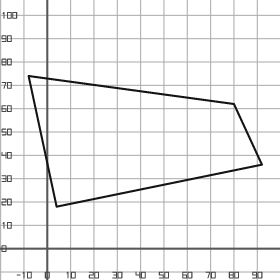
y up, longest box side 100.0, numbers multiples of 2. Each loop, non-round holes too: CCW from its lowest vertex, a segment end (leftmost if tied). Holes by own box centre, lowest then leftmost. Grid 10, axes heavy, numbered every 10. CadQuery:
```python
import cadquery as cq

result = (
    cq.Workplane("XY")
    .moveTo(4.0, 18.0)
    .lineTo(92.0, 36.0)
    .lineTo(80.0, 62.0)
    .lineTo(-8.0, 74.0)
    .close()
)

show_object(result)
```